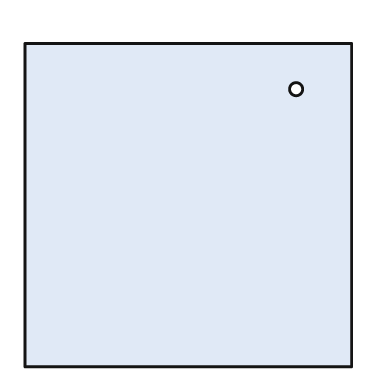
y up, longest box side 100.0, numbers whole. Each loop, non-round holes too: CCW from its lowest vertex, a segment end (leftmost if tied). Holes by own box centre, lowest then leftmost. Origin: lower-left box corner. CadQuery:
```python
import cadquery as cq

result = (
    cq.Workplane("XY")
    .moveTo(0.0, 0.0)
    .lineTo(100.0, 0.0)
    .lineTo(100.0, 99.0)
    .lineTo(0.0, 99.0)
    .close()
    .moveTo(83.0, 85.0)
    .circle(2.0)
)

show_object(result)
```